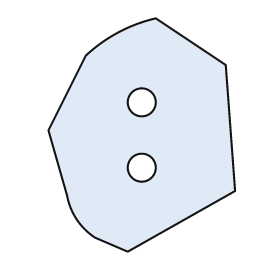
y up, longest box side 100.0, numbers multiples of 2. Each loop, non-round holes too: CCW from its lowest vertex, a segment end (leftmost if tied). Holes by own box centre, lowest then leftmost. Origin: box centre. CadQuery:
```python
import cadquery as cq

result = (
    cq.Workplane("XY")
    .moveTo(-6.0, -50.0)
    .lineTo(40.0, -24.0)
    .lineTo(36.0, 30.0)
    .lineTo(6.0, 50.0)
    .threePointArc((-10.0, 44.0), (-24.0, 34.0))
    .lineTo(-40.0, 2.0)
    .lineTo(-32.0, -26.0)
    .threePointArc((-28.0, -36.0), (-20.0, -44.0))
    .close()
    .moveTo(0.0, -14.0)
    .circle(6.0)
    .moveTo(0.0, 14.0)
    .circle(6.0)
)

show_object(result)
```